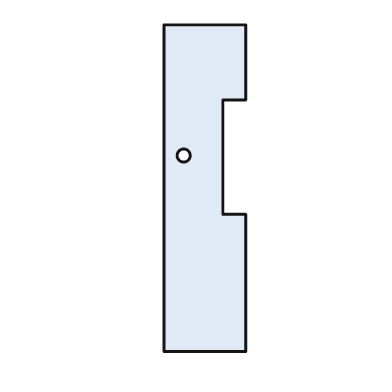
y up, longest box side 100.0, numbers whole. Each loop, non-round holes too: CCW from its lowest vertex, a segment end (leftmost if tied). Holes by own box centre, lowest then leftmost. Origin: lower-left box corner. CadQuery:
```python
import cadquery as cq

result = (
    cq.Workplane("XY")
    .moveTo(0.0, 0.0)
    .lineTo(25.0, 0.0)
    .lineTo(25.0, 42.0)
    .lineTo(18.0, 42.0)
    .lineTo(18.0, 77.0)
    .lineTo(25.0, 77.0)
    .lineTo(25.0, 100.0)
    .lineTo(0.0, 100.0)
    .close()
    .moveTo(6.0, 60.0)
    .circle(2.0)
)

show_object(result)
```